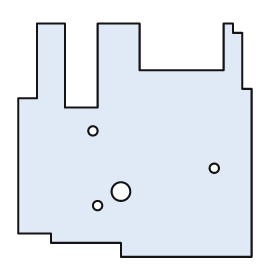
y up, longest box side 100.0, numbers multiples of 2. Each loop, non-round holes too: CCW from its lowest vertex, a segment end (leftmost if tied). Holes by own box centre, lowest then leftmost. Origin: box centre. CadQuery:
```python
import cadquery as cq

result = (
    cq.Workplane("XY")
    .moveTo(-6.0, -50.0)
    .lineTo(50.0, -50.0)
    .lineTo(50.0, 22.0)
    .lineTo(46.0, 22.0)
    .lineTo(46.0, 46.0)
    .lineTo(42.0, 46.0)
    .lineTo(42.0, 50.0)
    .lineTo(38.0, 50.0)
    .lineTo(38.0, 30.0)
    .lineTo(2.0, 30.0)
    .lineTo(2.0, 50.0)
    .lineTo(-16.0, 50.0)
    .lineTo(-16.0, 14.0)
    .lineTo(-30.0, 14.0)
    .lineTo(-30.0, 50.0)
    .lineTo(-42.0, 50.0)
    .lineTo(-42.0, 18.0)
    .lineTo(-50.0, 18.0)
    .lineTo(-50.0, -40.0)
    .lineTo(-36.0, -40.0)
    .lineTo(-36.0, -44.0)
    .lineTo(-6.0, -44.0)
    .close()
    .moveTo(-16.0, -28.0)
    .circle(2.0)
    .moveTo(-6.0, -22.0)
    .circle(4.0)
    .moveTo(34.0, -12.0)
    .circle(2.0)
    .moveTo(-18.0, 4.0)
    .circle(2.0)
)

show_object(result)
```